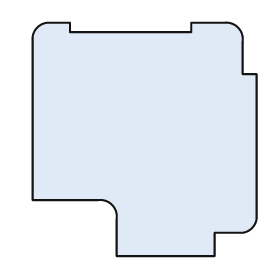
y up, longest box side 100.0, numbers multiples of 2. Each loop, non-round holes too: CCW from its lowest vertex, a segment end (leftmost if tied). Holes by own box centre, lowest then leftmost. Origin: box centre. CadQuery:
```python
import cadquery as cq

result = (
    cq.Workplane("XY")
    .moveTo(-12.0, -50.0)
    .lineTo(30.0, -50.0)
    .lineTo(30.0, -40.0)
    .lineTo(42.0, -40.0)
    .threePointArc((46.0, -38.0), (48.0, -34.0))
    .lineTo(48.0, 28.0)
    .lineTo(42.0, 28.0)
    .lineTo(42.0, 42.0)
    .threePointArc((40.0, 48.0), (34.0, 50.0))
    .lineTo(20.0, 50.0)
    .lineTo(20.0, 46.0)
    .lineTo(-32.0, 46.0)
    .lineTo(-32.0, 50.0)
    .lineTo(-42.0, 50.0)
    .threePointArc((-46.0, 48.0), (-48.0, 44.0))
    .lineTo(-48.0, -26.0)
    .lineTo(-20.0, -26.0)
    .threePointArc((-14.0, -28.0), (-12.0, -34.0))
    .close()
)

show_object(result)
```